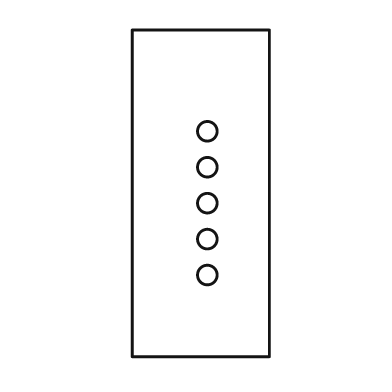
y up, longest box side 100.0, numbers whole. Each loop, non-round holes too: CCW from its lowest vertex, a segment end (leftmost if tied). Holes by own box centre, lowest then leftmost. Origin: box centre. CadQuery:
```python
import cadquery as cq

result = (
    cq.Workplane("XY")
    .moveTo(-21.0, -50.0)
    .lineTo(21.0, -50.0)
    .lineTo(21.0, 50.0)
    .lineTo(-21.0, 50.0)
    .close()
    .moveTo(2.0, -25.0)
    .circle(3.0)
    .moveTo(2.0, -14.0)
    .circle(3.0)
    .moveTo(2.0, -3.0)
    .circle(3.0)
    .moveTo(2.0, 8.0)
    .circle(3.0)
    .moveTo(2.0, 19.0)
    .circle(3.0)
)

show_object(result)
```